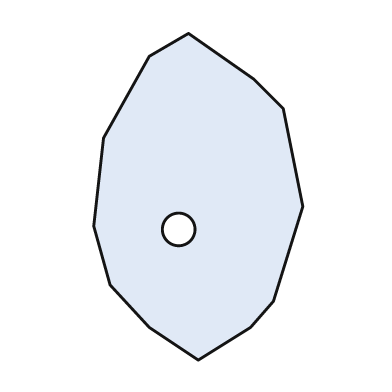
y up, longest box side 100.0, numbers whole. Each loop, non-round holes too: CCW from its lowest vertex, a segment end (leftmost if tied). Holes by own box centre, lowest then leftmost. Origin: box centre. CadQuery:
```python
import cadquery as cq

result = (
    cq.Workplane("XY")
    .moveTo(0.0, -50.0)
    .lineTo(16.0, -40.0)
    .lineTo(23.0, -32.0)
    .lineTo(32.0, -3.0)
    .lineTo(26.0, 27.0)
    .lineTo(17.0, 36.0)
    .lineTo(-3.0, 50.0)
    .lineTo(-15.0, 43.0)
    .lineTo(-29.0, 18.0)
    .lineTo(-32.0, -9.0)
    .lineTo(-27.0, -27.0)
    .lineTo(-15.0, -40.0)
    .close()
    .moveTo(-6.0, -10.0)
    .circle(5.0)
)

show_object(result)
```